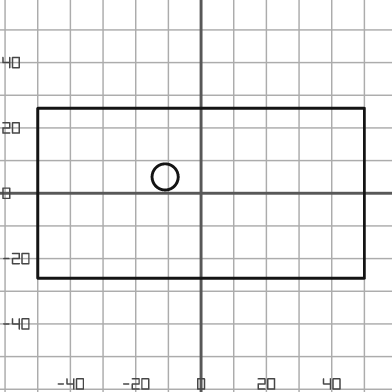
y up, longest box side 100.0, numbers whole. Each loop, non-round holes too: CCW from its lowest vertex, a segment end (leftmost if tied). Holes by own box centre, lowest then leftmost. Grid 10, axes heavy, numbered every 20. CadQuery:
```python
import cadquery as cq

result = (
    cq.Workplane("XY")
    .moveTo(-50.0, -26.0)
    .lineTo(50.0, -26.0)
    .lineTo(50.0, 26.0)
    .lineTo(-50.0, 26.0)
    .close()
    .moveTo(-11.0, 5.0)
    .circle(4.0)
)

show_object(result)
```